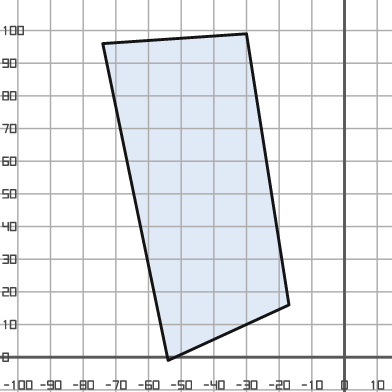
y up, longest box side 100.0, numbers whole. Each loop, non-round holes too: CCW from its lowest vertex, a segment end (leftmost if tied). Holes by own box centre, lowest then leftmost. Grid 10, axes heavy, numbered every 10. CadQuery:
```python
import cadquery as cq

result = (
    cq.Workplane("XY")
    .moveTo(-54.0, -1.0)
    .lineTo(-17.0, 16.0)
    .lineTo(-30.0, 99.0)
    .lineTo(-74.0, 96.0)
    .close()
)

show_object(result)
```